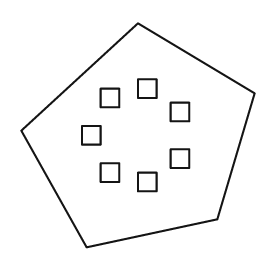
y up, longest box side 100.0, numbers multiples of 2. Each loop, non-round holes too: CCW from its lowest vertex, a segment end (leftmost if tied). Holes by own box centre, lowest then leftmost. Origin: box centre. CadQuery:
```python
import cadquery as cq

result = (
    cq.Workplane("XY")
    .moveTo(-22.0, -48.0)
    .lineTo(34.0, -36.0)
    .lineTo(50.0, 18.0)
    .lineTo(0.0, 48.0)
    .lineTo(-50.0, 2.0)
    .close()
    .moveTo(0.0, -24.0)
    .lineTo(8.0, -24.0)
    .lineTo(8.0, -16.0)
    .lineTo(0.0, -16.0)
    .close()
    .moveTo(-16.0, -20.0)
    .lineTo(-8.0, -20.0)
    .lineTo(-8.0, -12.0)
    .lineTo(-16.0, -12.0)
    .close()
    .moveTo(14.0, -14.0)
    .lineTo(22.0, -14.0)
    .lineTo(22.0, -6.0)
    .lineTo(14.0, -6.0)
    .close()
    .moveTo(-24.0, -4.0)
    .lineTo(-16.0, -4.0)
    .lineTo(-16.0, 4.0)
    .lineTo(-24.0, 4.0)
    .close()
    .moveTo(14.0, 6.0)
    .lineTo(22.0, 6.0)
    .lineTo(22.0, 14.0)
    .lineTo(14.0, 14.0)
    .close()
    .moveTo(-16.0, 12.0)
    .lineTo(-8.0, 12.0)
    .lineTo(-8.0, 20.0)
    .lineTo(-16.0, 20.0)
    .close()
    .moveTo(0.0, 16.0)
    .lineTo(8.0, 16.0)
    .lineTo(8.0, 24.0)
    .lineTo(0.0, 24.0)
    .close()
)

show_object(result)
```